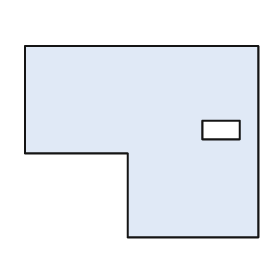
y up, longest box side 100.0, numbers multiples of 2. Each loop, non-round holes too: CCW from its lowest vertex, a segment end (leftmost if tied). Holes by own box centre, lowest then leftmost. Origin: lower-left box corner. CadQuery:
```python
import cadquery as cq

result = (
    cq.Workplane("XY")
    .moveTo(44.0, 0.0)
    .lineTo(100.0, 0.0)
    .lineTo(100.0, 82.0)
    .lineTo(0.0, 82.0)
    .lineTo(0.0, 36.0)
    .lineTo(44.0, 36.0)
    .close()
    .moveTo(76.0, 42.0)
    .lineTo(92.0, 42.0)
    .lineTo(92.0, 50.0)
    .lineTo(76.0, 50.0)
    .close()
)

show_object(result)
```